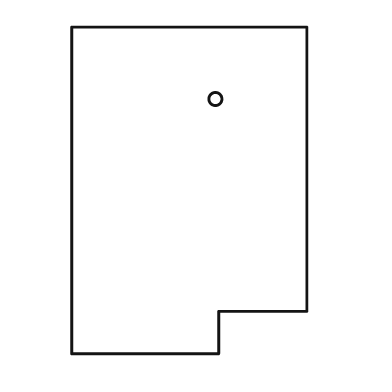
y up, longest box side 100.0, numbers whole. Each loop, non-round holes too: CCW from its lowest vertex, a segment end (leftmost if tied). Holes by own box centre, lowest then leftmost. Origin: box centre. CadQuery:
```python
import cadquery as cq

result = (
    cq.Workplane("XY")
    .moveTo(-36.0, -50.0)
    .lineTo(9.0, -50.0)
    .lineTo(9.0, -37.0)
    .lineTo(36.0, -37.0)
    .lineTo(36.0, 50.0)
    .lineTo(-36.0, 50.0)
    .close()
    .moveTo(8.0, 28.0)
    .circle(2.0)
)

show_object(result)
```